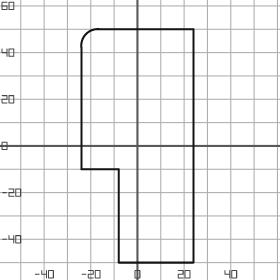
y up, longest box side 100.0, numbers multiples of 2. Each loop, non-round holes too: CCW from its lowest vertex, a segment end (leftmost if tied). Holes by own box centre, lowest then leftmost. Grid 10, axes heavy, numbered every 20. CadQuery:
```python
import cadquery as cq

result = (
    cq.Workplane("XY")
    .moveTo(-8.0, -50.0)
    .lineTo(24.0, -50.0)
    .lineTo(24.0, 50.0)
    .lineTo(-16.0, 50.0)
    .threePointArc((-22.0, 48.0), (-24.0, 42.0))
    .lineTo(-24.0, -10.0)
    .lineTo(-8.0, -10.0)
    .close()
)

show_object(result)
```